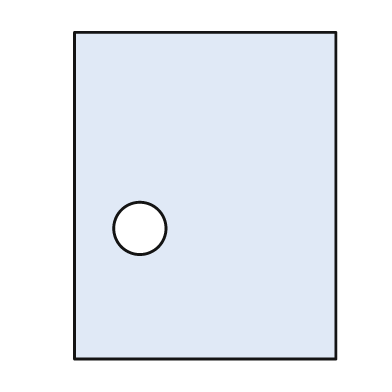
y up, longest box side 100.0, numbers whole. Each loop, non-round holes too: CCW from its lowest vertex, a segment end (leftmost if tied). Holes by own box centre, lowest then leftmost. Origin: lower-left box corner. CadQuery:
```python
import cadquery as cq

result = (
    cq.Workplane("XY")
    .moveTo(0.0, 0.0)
    .lineTo(80.0, 0.0)
    .lineTo(80.0, 100.0)
    .lineTo(0.0, 100.0)
    .close()
    .moveTo(20.0, 40.0)
    .circle(8.0)
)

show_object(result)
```